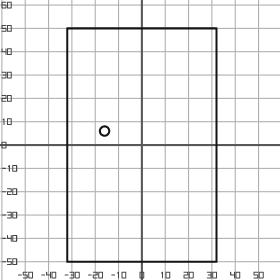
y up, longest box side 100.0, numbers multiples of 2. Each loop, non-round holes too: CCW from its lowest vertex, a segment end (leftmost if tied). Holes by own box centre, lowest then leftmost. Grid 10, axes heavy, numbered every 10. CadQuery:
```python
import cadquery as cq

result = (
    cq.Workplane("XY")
    .moveTo(-32.0, -50.0)
    .lineTo(32.0, -50.0)
    .lineTo(32.0, 50.0)
    .lineTo(-32.0, 50.0)
    .close()
    .moveTo(-16.0, 6.0)
    .circle(2.0)
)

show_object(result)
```